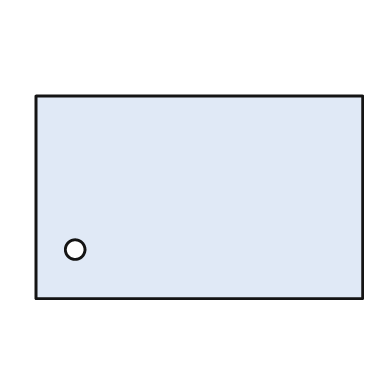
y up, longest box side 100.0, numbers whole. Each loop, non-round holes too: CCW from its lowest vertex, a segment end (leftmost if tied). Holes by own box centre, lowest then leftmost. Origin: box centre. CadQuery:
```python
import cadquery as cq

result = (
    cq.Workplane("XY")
    .moveTo(-50.0, -31.0)
    .lineTo(50.0, -31.0)
    .lineTo(50.0, 31.0)
    .lineTo(-50.0, 31.0)
    .close()
    .moveTo(-38.0, -16.0)
    .circle(3.0)
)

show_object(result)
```